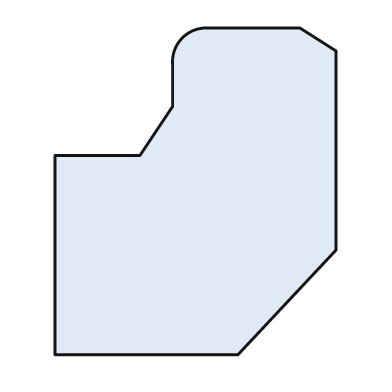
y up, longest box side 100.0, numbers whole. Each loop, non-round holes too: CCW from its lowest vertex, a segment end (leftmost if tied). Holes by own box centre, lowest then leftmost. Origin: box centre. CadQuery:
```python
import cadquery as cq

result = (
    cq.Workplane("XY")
    .moveTo(-43.0, -50.0)
    .lineTo(13.0, -50.0)
    .lineTo(43.0, -18.0)
    .lineTo(43.0, 43.0)
    .lineTo(32.0, 50.0)
    .lineTo(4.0, 50.0)
    .threePointArc((-4.0, 47.0), (-7.0, 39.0))
    .lineTo(-7.0, 26.0)
    .lineTo(-17.0, 11.0)
    .lineTo(-43.0, 11.0)
    .close()
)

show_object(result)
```